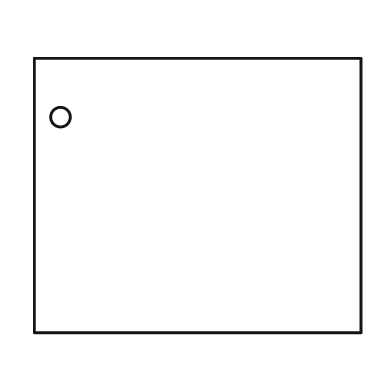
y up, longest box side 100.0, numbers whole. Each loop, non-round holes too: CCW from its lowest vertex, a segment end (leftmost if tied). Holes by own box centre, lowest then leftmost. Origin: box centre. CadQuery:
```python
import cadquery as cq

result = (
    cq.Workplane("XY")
    .moveTo(-50.0, -42.0)
    .lineTo(50.0, -42.0)
    .lineTo(50.0, 42.0)
    .lineTo(-50.0, 42.0)
    .close()
    .moveTo(-42.0, 24.0)
    .circle(3.0)
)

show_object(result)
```